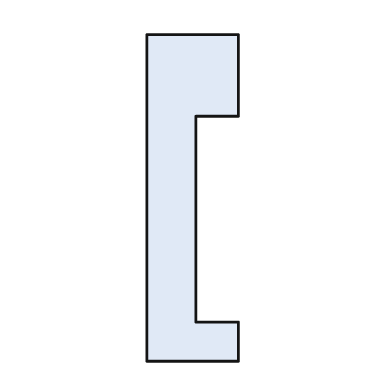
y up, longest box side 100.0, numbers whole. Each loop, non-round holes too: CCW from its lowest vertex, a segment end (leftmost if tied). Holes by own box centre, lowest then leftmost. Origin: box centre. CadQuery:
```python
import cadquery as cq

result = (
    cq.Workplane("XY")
    .moveTo(-14.0, -50.0)
    .lineTo(14.0, -50.0)
    .lineTo(14.0, -38.0)
    .lineTo(1.0, -38.0)
    .lineTo(1.0, 25.0)
    .lineTo(14.0, 25.0)
    .lineTo(14.0, 50.0)
    .lineTo(-14.0, 50.0)
    .close()
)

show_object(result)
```